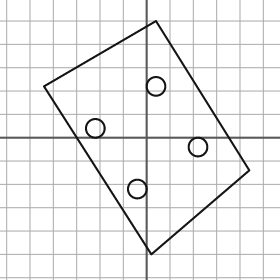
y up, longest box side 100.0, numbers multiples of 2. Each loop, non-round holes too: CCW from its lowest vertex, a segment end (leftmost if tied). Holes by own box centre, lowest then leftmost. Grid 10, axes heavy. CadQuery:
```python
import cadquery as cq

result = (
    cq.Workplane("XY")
    .moveTo(2.0, -50.0)
    .lineTo(44.0, -14.0)
    .lineTo(4.0, 50.0)
    .lineTo(-44.0, 22.0)
    .close()
    .moveTo(-4.0, -22.0)
    .circle(4.0)
    .moveTo(22.0, -4.0)
    .circle(4.0)
    .moveTo(-22.0, 4.0)
    .circle(4.0)
    .moveTo(4.0, 22.0)
    .circle(4.0)
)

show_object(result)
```